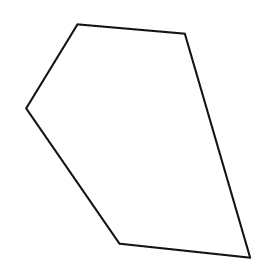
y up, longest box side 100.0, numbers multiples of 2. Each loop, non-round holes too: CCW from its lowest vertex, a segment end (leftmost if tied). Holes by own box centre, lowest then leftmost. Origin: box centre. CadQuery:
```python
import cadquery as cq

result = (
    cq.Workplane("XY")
    .moveTo(48.0, -50.0)
    .lineTo(20.0, 46.0)
    .lineTo(-26.0, 50.0)
    .lineTo(-48.0, 14.0)
    .lineTo(-8.0, -44.0)
    .close()
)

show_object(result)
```